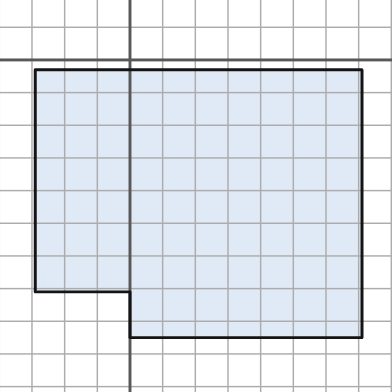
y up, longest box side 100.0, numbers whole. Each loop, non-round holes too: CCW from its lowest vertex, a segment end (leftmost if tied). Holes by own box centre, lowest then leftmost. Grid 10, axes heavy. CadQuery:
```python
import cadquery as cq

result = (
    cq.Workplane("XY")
    .moveTo(0.0, -85.0)
    .lineTo(71.0, -85.0)
    .lineTo(71.0, -3.0)
    .lineTo(-29.0, -3.0)
    .lineTo(-29.0, -71.0)
    .lineTo(0.0, -71.0)
    .close()
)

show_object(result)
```